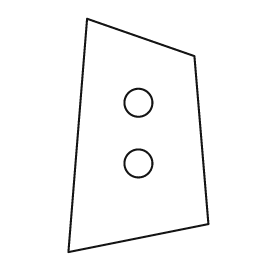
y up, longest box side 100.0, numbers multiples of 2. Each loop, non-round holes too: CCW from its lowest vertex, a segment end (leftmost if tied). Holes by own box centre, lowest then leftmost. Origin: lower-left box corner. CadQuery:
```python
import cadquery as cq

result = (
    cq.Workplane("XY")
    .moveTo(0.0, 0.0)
    .lineTo(60.0, 12.0)
    .lineTo(54.0, 84.0)
    .lineTo(8.0, 100.0)
    .close()
    .moveTo(30.0, 38.0)
    .circle(6.0)
    .moveTo(30.0, 64.0)
    .circle(6.0)
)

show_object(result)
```